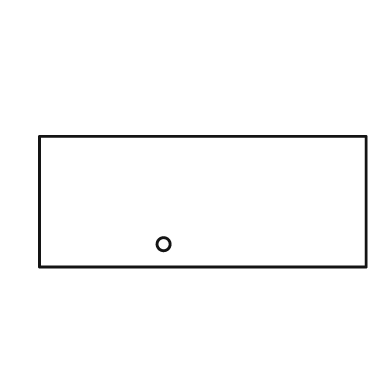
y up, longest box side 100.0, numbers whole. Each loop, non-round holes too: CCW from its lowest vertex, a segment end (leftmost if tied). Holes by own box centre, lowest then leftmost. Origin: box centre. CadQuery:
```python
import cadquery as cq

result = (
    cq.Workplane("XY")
    .moveTo(-50.0, -20.0)
    .lineTo(50.0, -20.0)
    .lineTo(50.0, 20.0)
    .lineTo(-50.0, 20.0)
    .close()
    .moveTo(-12.0, -13.0)
    .circle(2.0)
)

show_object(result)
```